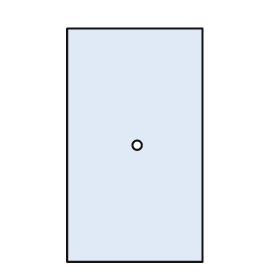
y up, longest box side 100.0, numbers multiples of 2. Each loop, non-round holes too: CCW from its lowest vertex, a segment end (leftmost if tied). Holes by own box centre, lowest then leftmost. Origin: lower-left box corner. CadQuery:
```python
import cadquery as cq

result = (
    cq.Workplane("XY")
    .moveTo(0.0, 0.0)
    .lineTo(58.0, 0.0)
    .lineTo(58.0, 100.0)
    .lineTo(0.0, 100.0)
    .close()
    .moveTo(30.0, 50.0)
    .circle(2.0)
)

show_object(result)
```